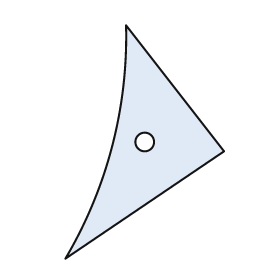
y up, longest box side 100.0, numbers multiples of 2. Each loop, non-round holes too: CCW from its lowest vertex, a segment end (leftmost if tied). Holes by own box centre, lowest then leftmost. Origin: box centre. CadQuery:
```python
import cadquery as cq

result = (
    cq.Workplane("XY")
    .moveTo(-34.0, -50.0)
    .lineTo(34.0, -4.0)
    .lineTo(-8.0, 50.0)
    .threePointArc((-14.0, -2.0), (-34.0, -50.0))
    .close()
    .moveTo(0.0, 0.0)
    .circle(4.0)
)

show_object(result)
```